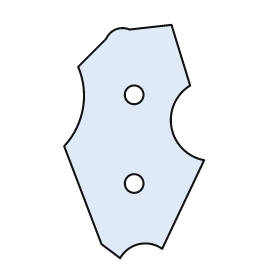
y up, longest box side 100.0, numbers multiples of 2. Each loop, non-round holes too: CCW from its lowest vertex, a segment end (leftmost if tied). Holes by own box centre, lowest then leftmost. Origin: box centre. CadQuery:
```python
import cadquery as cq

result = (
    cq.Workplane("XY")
    .moveTo(-6.0, -50.0)
    .threePointArc((2.0, -44.0), (12.0, -46.0))
    .lineTo(30.0, -8.0)
    .threePointArc((16.0, 6.0), (24.0, 24.0))
    .lineTo(16.0, 50.0)
    .lineTo(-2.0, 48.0)
    .threePointArc((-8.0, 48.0), (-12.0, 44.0))
    .lineTo(-24.0, 32.0)
    .threePointArc((-22.0, 14.0), (-30.0, -2.0))
    .lineTo(-14.0, -44.0)
    .close()
    .moveTo(0.0, -18.0)
    .circle(4.0)
    .moveTo(0.0, 20.0)
    .circle(4.0)
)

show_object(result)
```